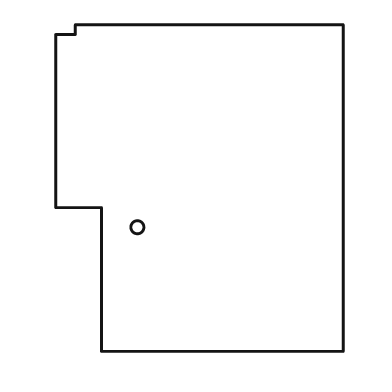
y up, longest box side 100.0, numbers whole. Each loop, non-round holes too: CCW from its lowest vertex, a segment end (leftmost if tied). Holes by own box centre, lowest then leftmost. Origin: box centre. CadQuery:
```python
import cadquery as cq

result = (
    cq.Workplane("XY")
    .moveTo(-30.0, -50.0)
    .lineTo(44.0, -50.0)
    .lineTo(44.0, 50.0)
    .lineTo(-38.0, 50.0)
    .lineTo(-38.0, 47.0)
    .lineTo(-44.0, 47.0)
    .lineTo(-44.0, -6.0)
    .lineTo(-30.0, -6.0)
    .close()
    .moveTo(-19.0, -12.0)
    .circle(2.0)
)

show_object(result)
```